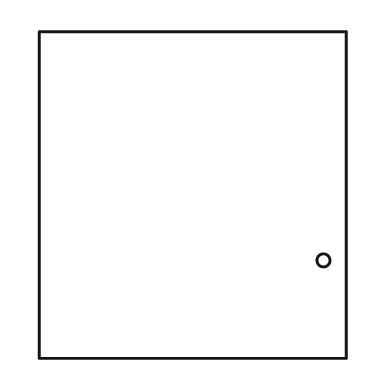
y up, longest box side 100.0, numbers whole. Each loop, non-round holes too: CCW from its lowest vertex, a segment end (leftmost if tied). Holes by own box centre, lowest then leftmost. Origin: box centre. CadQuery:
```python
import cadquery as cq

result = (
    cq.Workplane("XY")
    .moveTo(-47.0, -50.0)
    .lineTo(47.0, -50.0)
    .lineTo(47.0, 50.0)
    .lineTo(-47.0, 50.0)
    .close()
    .moveTo(40.0, -20.0)
    .circle(2.0)
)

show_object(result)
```